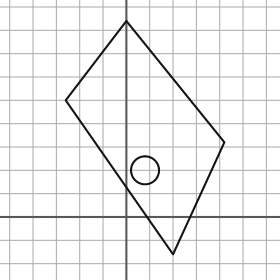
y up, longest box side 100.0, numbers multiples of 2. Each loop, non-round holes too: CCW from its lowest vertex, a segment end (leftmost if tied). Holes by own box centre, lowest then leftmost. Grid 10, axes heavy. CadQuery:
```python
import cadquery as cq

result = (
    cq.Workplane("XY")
    .moveTo(20.0, -16.0)
    .lineTo(42.0, 32.0)
    .lineTo(0.0, 84.0)
    .lineTo(-26.0, 50.0)
    .close()
    .moveTo(8.0, 20.0)
    .circle(6.0)
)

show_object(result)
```